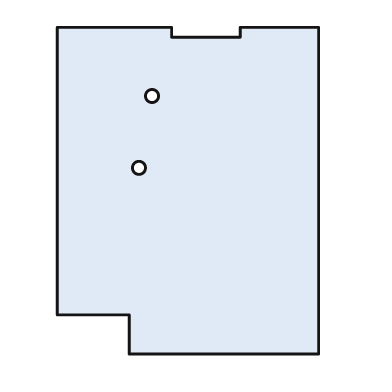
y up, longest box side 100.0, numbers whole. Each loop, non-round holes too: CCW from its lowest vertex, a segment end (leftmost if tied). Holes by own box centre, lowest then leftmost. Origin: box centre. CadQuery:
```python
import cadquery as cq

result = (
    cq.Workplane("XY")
    .moveTo(-18.0, -50.0)
    .lineTo(40.0, -50.0)
    .lineTo(40.0, 50.0)
    .lineTo(16.0, 50.0)
    .lineTo(16.0, 47.0)
    .lineTo(-5.0, 47.0)
    .lineTo(-5.0, 50.0)
    .lineTo(-40.0, 50.0)
    .lineTo(-40.0, -38.0)
    .lineTo(-18.0, -38.0)
    .close()
    .moveTo(-15.0, 7.0)
    .circle(2.0)
    .moveTo(-11.0, 29.0)
    .circle(2.0)
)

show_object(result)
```